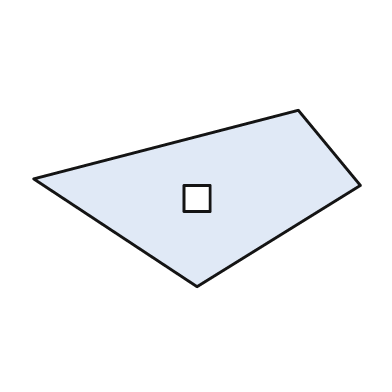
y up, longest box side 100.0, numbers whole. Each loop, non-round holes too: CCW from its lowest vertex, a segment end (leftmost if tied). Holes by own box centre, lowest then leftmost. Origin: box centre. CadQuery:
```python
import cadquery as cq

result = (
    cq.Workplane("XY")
    .moveTo(0.0, -27.0)
    .lineTo(50.0, 4.0)
    .lineTo(31.0, 27.0)
    .lineTo(-50.0, 6.0)
    .close()
    .moveTo(-4.0, -4.0)
    .lineTo(4.0, -4.0)
    .lineTo(4.0, 4.0)
    .lineTo(-4.0, 4.0)
    .close()
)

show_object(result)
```